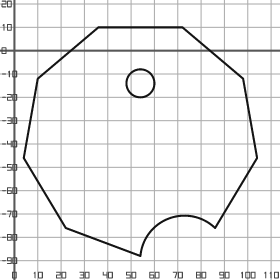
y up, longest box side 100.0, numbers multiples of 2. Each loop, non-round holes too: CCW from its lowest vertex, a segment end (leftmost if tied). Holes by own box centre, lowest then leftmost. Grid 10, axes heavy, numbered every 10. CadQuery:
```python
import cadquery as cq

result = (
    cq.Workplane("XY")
    .moveTo(54.0, -88.0)
    .threePointArc((66.0, -72.0), (86.0, -76.0))
    .lineTo(104.0, -46.0)
    .lineTo(98.0, -12.0)
    .lineTo(72.0, 10.0)
    .lineTo(36.0, 10.0)
    .lineTo(10.0, -12.0)
    .lineTo(4.0, -46.0)
    .lineTo(22.0, -76.0)
    .close()
    .moveTo(54.0, -14.0)
    .circle(6.0)
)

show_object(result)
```